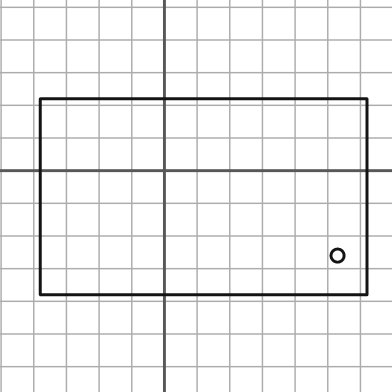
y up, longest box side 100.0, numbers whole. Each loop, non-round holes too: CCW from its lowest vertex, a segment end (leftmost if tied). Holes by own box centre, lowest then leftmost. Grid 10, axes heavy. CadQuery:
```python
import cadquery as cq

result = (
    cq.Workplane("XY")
    .moveTo(-38.0, -38.0)
    .lineTo(62.0, -38.0)
    .lineTo(62.0, 22.0)
    .lineTo(-38.0, 22.0)
    .close()
    .moveTo(53.0, -26.0)
    .circle(2.0)
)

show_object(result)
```